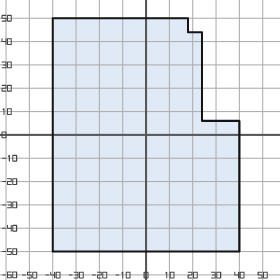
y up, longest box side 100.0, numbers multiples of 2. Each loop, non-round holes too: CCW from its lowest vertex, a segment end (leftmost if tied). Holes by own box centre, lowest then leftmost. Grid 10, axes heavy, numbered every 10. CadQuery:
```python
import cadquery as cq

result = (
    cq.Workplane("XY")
    .moveTo(-40.0, -50.0)
    .lineTo(40.0, -50.0)
    .lineTo(40.0, 6.0)
    .lineTo(24.0, 6.0)
    .lineTo(24.0, 44.0)
    .lineTo(18.0, 44.0)
    .lineTo(18.0, 50.0)
    .lineTo(-40.0, 50.0)
    .close()
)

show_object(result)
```